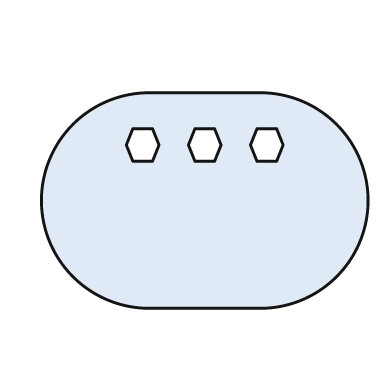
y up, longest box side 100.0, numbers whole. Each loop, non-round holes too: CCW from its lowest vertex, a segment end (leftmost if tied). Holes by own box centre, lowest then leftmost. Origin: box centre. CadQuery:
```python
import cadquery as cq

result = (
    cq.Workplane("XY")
    .moveTo(-17.0, -33.0)
    .lineTo(17.0, -33.0)
    .threePointArc((50.0, 0.0), (17.0, 33.0))
    .lineTo(-17.0, 33.0)
    .threePointArc((-50.0, 0.0), (-17.0, -33.0))
    .close()
    .moveTo(-22.0, 12.0)
    .lineTo(-16.0, 12.0)
    .lineTo(-14.0, 17.0)
    .lineTo(-16.0, 22.0)
    .lineTo(-22.0, 22.0)
    .lineTo(-24.0, 17.0)
    .close()
    .moveTo(-3.0, 12.0)
    .lineTo(3.0, 12.0)
    .lineTo(5.0, 17.0)
    .lineTo(3.0, 22.0)
    .lineTo(-3.0, 22.0)
    .lineTo(-5.0, 17.0)
    .close()
    .moveTo(16.0, 12.0)
    .lineTo(22.0, 12.0)
    .lineTo(24.0, 17.0)
    .lineTo(22.0, 22.0)
    .lineTo(16.0, 22.0)
    .lineTo(14.0, 17.0)
    .close()
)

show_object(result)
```